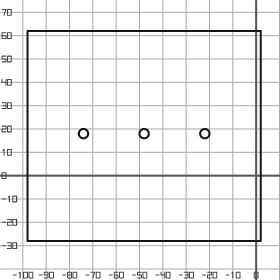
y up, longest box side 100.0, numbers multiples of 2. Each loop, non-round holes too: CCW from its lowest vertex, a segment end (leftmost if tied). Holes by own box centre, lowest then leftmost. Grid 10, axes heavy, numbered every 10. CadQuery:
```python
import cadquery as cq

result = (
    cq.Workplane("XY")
    .moveTo(-98.0, -28.0)
    .lineTo(2.0, -28.0)
    .lineTo(2.0, 62.0)
    .lineTo(-98.0, 62.0)
    .close()
    .moveTo(-74.0, 18.0)
    .circle(2.0)
    .moveTo(-48.0, 18.0)
    .circle(2.0)
    .moveTo(-22.0, 18.0)
    .circle(2.0)
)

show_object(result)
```